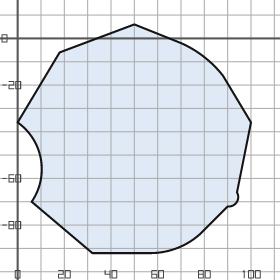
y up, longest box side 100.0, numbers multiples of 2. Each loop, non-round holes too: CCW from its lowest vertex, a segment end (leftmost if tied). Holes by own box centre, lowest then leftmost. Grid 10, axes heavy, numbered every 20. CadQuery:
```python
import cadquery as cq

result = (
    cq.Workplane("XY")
    .moveTo(32.0, -92.0)
    .lineTo(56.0, -92.0)
    .threePointArc((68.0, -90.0), (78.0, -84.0))
    .lineTo(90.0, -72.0)
    .threePointArc((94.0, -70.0), (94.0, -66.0))
    .lineTo(100.0, -36.0)
    .lineTo(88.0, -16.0)
    .threePointArc((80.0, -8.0), (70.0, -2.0))
    .lineTo(50.0, 6.0)
    .lineTo(18.0, -6.0)
    .lineTo(0.0, -36.0)
    .threePointArc((10.0, -52.0), (6.0, -70.0))
    .close()
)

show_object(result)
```